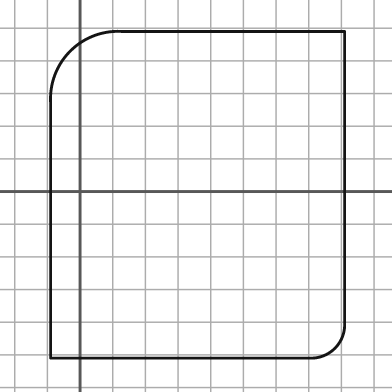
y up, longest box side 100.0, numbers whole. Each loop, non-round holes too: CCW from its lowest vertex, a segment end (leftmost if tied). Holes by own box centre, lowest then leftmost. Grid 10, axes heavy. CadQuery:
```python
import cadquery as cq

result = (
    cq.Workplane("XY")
    .moveTo(-9.0, -51.0)
    .lineTo(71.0, -51.0)
    .threePointArc((78.0, -48.0), (81.0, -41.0))
    .lineTo(81.0, 49.0)
    .lineTo(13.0, 49.0)
    .threePointArc((-3.0, 43.0), (-9.0, 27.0))
    .close()
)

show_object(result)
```